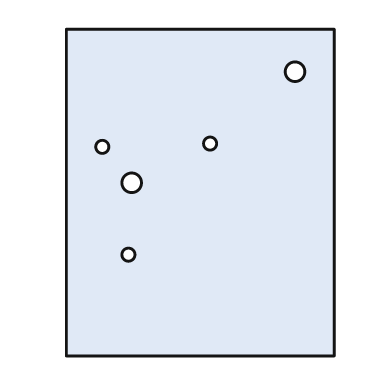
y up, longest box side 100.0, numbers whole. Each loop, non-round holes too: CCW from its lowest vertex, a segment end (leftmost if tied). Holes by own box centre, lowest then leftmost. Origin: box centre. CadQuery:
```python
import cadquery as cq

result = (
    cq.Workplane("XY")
    .moveTo(-41.0, -50.0)
    .lineTo(41.0, -50.0)
    .lineTo(41.0, 50.0)
    .lineTo(-41.0, 50.0)
    .close()
    .moveTo(-22.0, -19.0)
    .circle(2.0)
    .moveTo(-21.0, 3.0)
    .circle(3.0)
    .moveTo(-30.0, 14.0)
    .circle(2.0)
    .moveTo(3.0, 15.0)
    .circle(2.0)
    .moveTo(29.0, 37.0)
    .circle(3.0)
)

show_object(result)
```